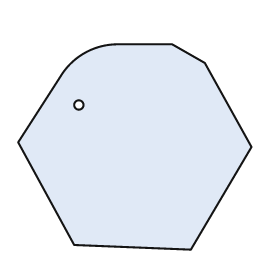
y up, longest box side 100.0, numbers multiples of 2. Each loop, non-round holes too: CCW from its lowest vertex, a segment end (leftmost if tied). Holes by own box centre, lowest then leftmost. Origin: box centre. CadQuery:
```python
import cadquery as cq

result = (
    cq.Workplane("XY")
    .moveTo(24.0, -44.0)
    .lineTo(50.0, 0.0)
    .lineTo(30.0, 36.0)
    .lineTo(16.0, 44.0)
    .lineTo(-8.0, 44.0)
    .threePointArc((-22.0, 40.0), (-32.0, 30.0))
    .lineTo(-50.0, 2.0)
    .lineTo(-26.0, -42.0)
    .close()
    .moveTo(-24.0, 18.0)
    .circle(2.0)
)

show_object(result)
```